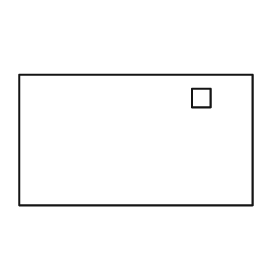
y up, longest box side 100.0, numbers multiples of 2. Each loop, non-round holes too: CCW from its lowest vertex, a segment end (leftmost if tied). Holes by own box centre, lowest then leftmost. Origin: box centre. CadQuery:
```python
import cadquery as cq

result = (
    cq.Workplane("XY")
    .moveTo(-50.0, -28.0)
    .lineTo(50.0, -28.0)
    .lineTo(50.0, 28.0)
    .lineTo(-50.0, 28.0)
    .close()
    .moveTo(24.0, 14.0)
    .lineTo(32.0, 14.0)
    .lineTo(32.0, 22.0)
    .lineTo(24.0, 22.0)
    .close()
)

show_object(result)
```